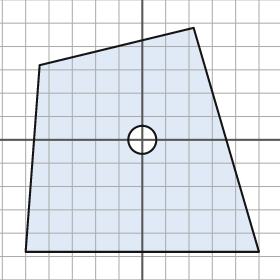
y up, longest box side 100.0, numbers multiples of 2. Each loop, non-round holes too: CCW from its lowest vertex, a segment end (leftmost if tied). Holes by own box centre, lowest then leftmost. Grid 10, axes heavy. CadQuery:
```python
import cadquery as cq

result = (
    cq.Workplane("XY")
    .moveTo(-50.0, -48.0)
    .lineTo(50.0, -48.0)
    .lineTo(22.0, 48.0)
    .lineTo(-44.0, 32.0)
    .close()
    .moveTo(0.0, 0.0)
    .circle(6.0)
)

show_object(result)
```